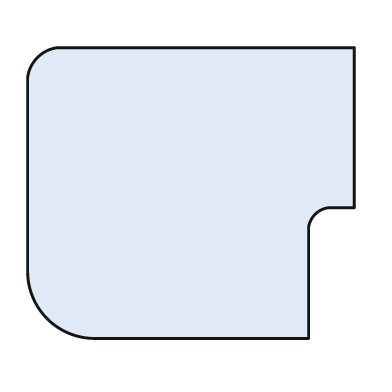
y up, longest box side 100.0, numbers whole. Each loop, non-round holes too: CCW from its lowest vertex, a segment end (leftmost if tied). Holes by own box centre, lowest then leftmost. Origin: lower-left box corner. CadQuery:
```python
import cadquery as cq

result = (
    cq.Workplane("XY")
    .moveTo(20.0, 0.0)
    .lineTo(86.0, 0.0)
    .lineTo(86.0, 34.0)
    .threePointArc((88.0, 38.0), (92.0, 40.0))
    .lineTo(100.0, 40.0)
    .lineTo(100.0, 89.0)
    .lineTo(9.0, 89.0)
    .threePointArc((3.0, 86.0), (0.0, 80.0))
    .lineTo(0.0, 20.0)
    .threePointArc((6.0, 6.0), (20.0, 0.0))
    .close()
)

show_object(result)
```